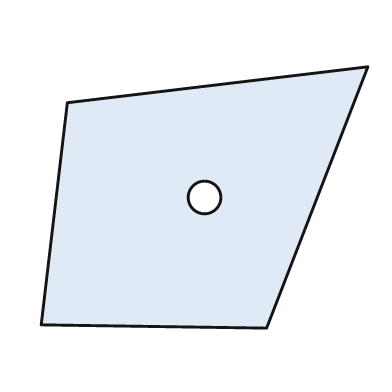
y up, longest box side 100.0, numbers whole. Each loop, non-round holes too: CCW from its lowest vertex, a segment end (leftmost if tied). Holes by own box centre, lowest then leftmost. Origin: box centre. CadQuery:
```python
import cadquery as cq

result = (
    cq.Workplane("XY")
    .moveTo(19.0, -40.0)
    .lineTo(50.0, 40.0)
    .lineTo(-42.0, 29.0)
    .lineTo(-50.0, -39.0)
    .close()
    .moveTo(0.0, 0.0)
    .circle(5.0)
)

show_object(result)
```